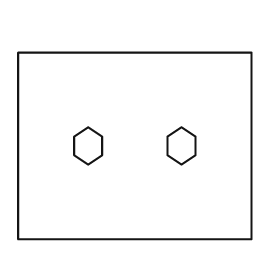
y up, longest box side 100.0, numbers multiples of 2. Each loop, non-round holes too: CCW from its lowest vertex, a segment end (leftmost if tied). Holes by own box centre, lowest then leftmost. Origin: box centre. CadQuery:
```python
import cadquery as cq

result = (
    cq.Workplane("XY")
    .moveTo(-50.0, -40.0)
    .lineTo(50.0, -40.0)
    .lineTo(50.0, 40.0)
    .lineTo(-50.0, 40.0)
    .close()
    .moveTo(-20.0, -8.0)
    .lineTo(-14.0, -4.0)
    .lineTo(-14.0, 4.0)
    .lineTo(-20.0, 8.0)
    .lineTo(-26.0, 4.0)
    .lineTo(-26.0, -4.0)
    .close()
    .moveTo(20.0, -8.0)
    .lineTo(26.0, -4.0)
    .lineTo(26.0, 4.0)
    .lineTo(20.0, 8.0)
    .lineTo(14.0, 4.0)
    .lineTo(14.0, -4.0)
    .close()
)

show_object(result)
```